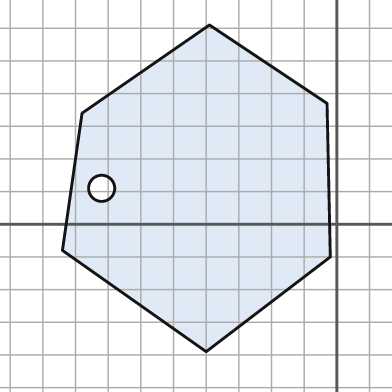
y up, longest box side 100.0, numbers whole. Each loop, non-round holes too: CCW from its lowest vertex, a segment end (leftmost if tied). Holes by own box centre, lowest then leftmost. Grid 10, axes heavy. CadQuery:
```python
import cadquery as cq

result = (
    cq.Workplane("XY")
    .moveTo(-40.0, -39.0)
    .lineTo(-2.0, -10.0)
    .lineTo(-3.0, 37.0)
    .lineTo(-39.0, 61.0)
    .lineTo(-78.0, 34.0)
    .lineTo(-84.0, -8.0)
    .close()
    .moveTo(-72.0, 11.0)
    .circle(4.0)
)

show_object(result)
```